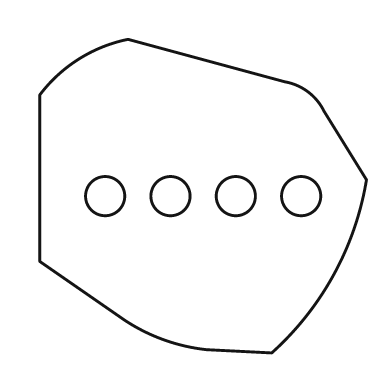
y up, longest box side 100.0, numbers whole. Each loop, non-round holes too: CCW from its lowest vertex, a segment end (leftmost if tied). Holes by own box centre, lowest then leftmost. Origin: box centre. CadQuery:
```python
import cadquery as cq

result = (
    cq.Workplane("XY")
    .moveTo(21.0, -48.0)
    .threePointArc((40.0, -24.0), (50.0, 5.0))
    .lineTo(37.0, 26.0)
    .threePointArc((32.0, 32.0), (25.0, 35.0))
    .lineTo(-23.0, 48.0)
    .threePointArc((-38.0, 42.0), (-50.0, 31.0))
    .lineTo(-50.0, -20.0)
    .lineTo(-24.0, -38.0)
    .threePointArc((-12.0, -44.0), (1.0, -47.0))
    .close()
    .moveTo(-30.0, 0.0)
    .circle(6.0)
    .moveTo(-10.0, 0.0)
    .circle(6.0)
    .moveTo(10.0, 0.0)
    .circle(6.0)
    .moveTo(30.0, 0.0)
    .circle(6.0)
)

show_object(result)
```